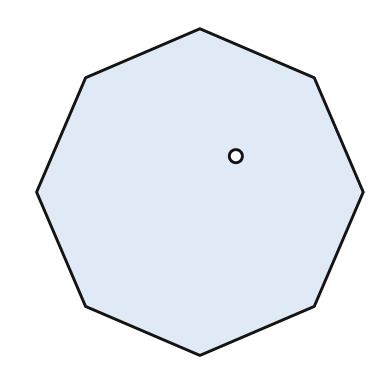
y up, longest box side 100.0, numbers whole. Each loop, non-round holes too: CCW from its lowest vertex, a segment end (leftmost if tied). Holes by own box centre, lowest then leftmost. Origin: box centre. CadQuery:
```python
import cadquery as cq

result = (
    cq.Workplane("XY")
    .moveTo(0.0, -50.0)
    .lineTo(35.0, -35.0)
    .lineTo(50.0, 0.0)
    .lineTo(35.0, 35.0)
    .lineTo(0.0, 50.0)
    .lineTo(-35.0, 35.0)
    .lineTo(-50.0, 0.0)
    .lineTo(-35.0, -35.0)
    .close()
    .moveTo(11.0, 11.0)
    .circle(2.0)
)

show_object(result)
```